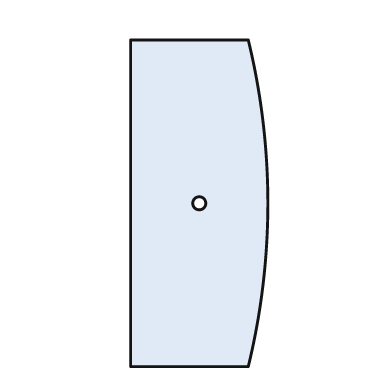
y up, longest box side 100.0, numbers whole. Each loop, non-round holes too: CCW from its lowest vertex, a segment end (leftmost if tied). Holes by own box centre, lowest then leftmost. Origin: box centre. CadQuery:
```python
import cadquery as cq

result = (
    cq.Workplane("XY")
    .moveTo(-21.0, -50.0)
    .lineTo(15.0, -50.0)
    .threePointArc((21.0, 0.0), (15.0, 50.0))
    .lineTo(-21.0, 50.0)
    .close()
    .moveTo(0.0, 0.0)
    .circle(2.0)
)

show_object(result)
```